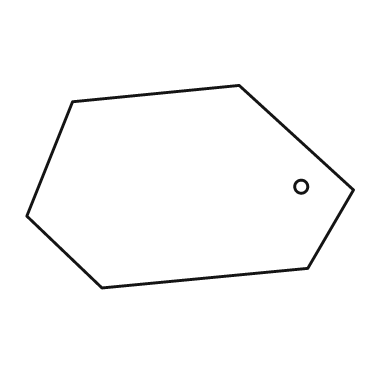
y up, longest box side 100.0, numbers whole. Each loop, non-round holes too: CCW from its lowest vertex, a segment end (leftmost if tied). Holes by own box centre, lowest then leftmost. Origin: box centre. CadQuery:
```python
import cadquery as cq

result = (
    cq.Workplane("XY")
    .moveTo(-27.0, -31.0)
    .lineTo(36.0, -25.0)
    .lineTo(50.0, -1.0)
    .lineTo(15.0, 31.0)
    .lineTo(-36.0, 26.0)
    .lineTo(-50.0, -9.0)
    .close()
    .moveTo(34.0, 0.0)
    .circle(2.0)
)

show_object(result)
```